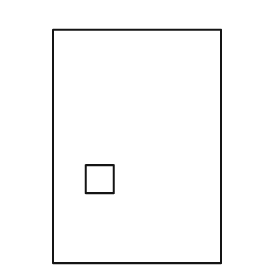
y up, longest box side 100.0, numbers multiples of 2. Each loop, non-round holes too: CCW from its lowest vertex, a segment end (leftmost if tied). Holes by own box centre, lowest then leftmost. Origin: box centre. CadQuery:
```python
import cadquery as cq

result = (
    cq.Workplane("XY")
    .moveTo(-36.0, -50.0)
    .lineTo(36.0, -50.0)
    .lineTo(36.0, 50.0)
    .lineTo(-36.0, 50.0)
    .close()
    .moveTo(-22.0, -20.0)
    .lineTo(-10.0, -20.0)
    .lineTo(-10.0, -8.0)
    .lineTo(-22.0, -8.0)
    .close()
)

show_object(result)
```